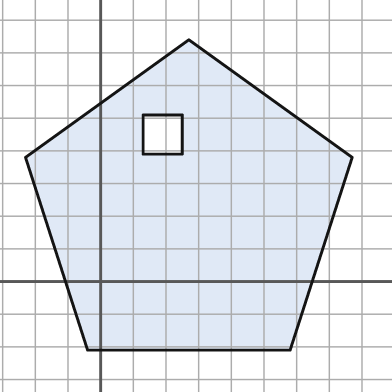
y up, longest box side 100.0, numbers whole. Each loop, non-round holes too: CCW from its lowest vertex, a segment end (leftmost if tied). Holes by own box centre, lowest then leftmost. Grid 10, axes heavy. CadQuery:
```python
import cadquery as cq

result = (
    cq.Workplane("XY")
    .moveTo(-4.0, -21.0)
    .lineTo(58.0, -21.0)
    .lineTo(77.0, 38.0)
    .lineTo(27.0, 74.0)
    .lineTo(-23.0, 38.0)
    .close()
    .moveTo(13.0, 39.0)
    .lineTo(25.0, 39.0)
    .lineTo(25.0, 51.0)
    .lineTo(13.0, 51.0)
    .close()
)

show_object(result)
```